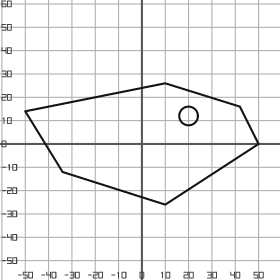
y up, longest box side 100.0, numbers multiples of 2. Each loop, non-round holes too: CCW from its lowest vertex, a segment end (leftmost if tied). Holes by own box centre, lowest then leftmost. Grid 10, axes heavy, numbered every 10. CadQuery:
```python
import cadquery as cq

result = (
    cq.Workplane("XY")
    .moveTo(10.0, -26.0)
    .lineTo(50.0, 0.0)
    .lineTo(42.0, 16.0)
    .lineTo(10.0, 26.0)
    .lineTo(-50.0, 14.0)
    .lineTo(-34.0, -12.0)
    .close()
    .moveTo(20.0, 12.0)
    .circle(4.0)
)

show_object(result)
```